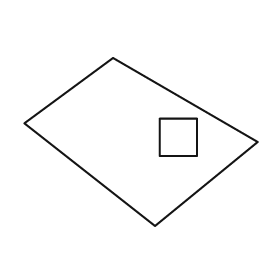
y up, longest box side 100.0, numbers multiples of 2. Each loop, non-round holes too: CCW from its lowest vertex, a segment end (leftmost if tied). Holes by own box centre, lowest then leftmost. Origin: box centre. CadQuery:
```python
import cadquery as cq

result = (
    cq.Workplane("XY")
    .moveTo(6.0, -36.0)
    .lineTo(50.0, 0.0)
    .lineTo(-12.0, 36.0)
    .lineTo(-50.0, 8.0)
    .close()
    .moveTo(8.0, -6.0)
    .lineTo(24.0, -6.0)
    .lineTo(24.0, 10.0)
    .lineTo(8.0, 10.0)
    .close()
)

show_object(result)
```